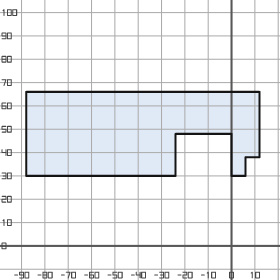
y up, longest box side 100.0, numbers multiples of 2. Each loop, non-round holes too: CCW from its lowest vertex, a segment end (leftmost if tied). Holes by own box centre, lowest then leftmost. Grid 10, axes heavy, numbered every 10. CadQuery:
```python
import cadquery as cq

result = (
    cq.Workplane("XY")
    .moveTo(-88.0, 30.0)
    .lineTo(-24.0, 30.0)
    .lineTo(-24.0, 48.0)
    .lineTo(0.0, 48.0)
    .lineTo(0.0, 30.0)
    .lineTo(6.0, 30.0)
    .lineTo(6.0, 38.0)
    .lineTo(12.0, 38.0)
    .lineTo(12.0, 66.0)
    .lineTo(-88.0, 66.0)
    .close()
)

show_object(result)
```